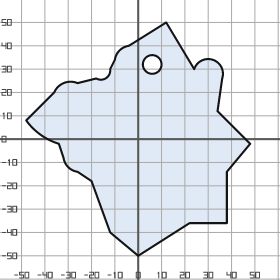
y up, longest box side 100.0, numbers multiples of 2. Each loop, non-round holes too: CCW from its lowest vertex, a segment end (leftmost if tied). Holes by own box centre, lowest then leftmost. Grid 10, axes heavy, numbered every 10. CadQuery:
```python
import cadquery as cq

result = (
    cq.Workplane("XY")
    .moveTo(0.0, -50.0)
    .lineTo(22.0, -36.0)
    .lineTo(38.0, -36.0)
    .lineTo(38.0, -14.0)
    .lineTo(48.0, -2.0)
    .lineTo(34.0, 12.0)
    .lineTo(36.0, 26.0)
    .threePointArc((32.0, 34.0), (24.0, 30.0))
    .lineTo(12.0, 50.0)
    .lineTo(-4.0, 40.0)
    .threePointArc((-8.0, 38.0), (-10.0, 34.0))
    .lineTo(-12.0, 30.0)
    .threePointArc((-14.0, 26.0), (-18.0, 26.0))
    .lineTo(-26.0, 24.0)
    .threePointArc((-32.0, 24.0), (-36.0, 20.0))
    .lineTo(-48.0, 8.0)
    .threePointArc((-42.0, 2.0), (-34.0, -2.0))
    .lineTo(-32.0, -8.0)
    .threePointArc((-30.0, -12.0), (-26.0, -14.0))
    .lineTo(-20.0, -18.0)
    .lineTo(-12.0, -40.0)
    .close()
    .moveTo(6.0, 32.0)
    .circle(4.0)
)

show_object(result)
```